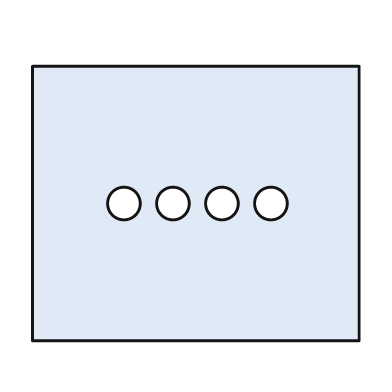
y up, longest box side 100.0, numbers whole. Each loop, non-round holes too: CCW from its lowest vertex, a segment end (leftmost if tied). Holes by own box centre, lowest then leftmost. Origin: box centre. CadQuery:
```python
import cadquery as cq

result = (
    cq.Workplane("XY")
    .moveTo(-50.0, -42.0)
    .lineTo(50.0, -42.0)
    .lineTo(50.0, 42.0)
    .lineTo(-50.0, 42.0)
    .close()
    .moveTo(-22.0, 0.0)
    .circle(5.0)
    .moveTo(-7.0, 0.0)
    .circle(5.0)
    .moveTo(8.0, 0.0)
    .circle(5.0)
    .moveTo(23.0, 0.0)
    .circle(5.0)
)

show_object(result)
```